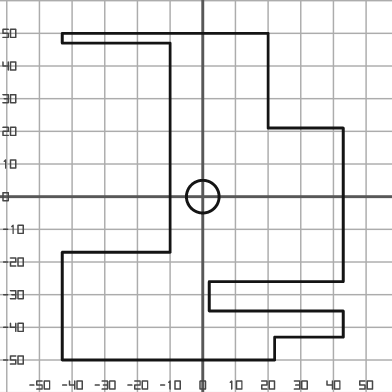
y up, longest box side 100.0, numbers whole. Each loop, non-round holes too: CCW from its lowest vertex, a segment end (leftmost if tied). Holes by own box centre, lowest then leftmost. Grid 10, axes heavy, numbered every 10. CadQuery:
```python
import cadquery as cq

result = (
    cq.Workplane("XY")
    .moveTo(-43.0, -50.0)
    .lineTo(22.0, -50.0)
    .lineTo(22.0, -43.0)
    .lineTo(43.0, -43.0)
    .lineTo(43.0, -35.0)
    .lineTo(2.0, -35.0)
    .lineTo(2.0, -26.0)
    .lineTo(43.0, -26.0)
    .lineTo(43.0, 21.0)
    .lineTo(20.0, 21.0)
    .lineTo(20.0, 50.0)
    .lineTo(-43.0, 50.0)
    .lineTo(-43.0, 47.0)
    .lineTo(-10.0, 47.0)
    .lineTo(-10.0, -17.0)
    .lineTo(-43.0, -17.0)
    .close()
    .moveTo(0.0, 0.0)
    .circle(5.0)
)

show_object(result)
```